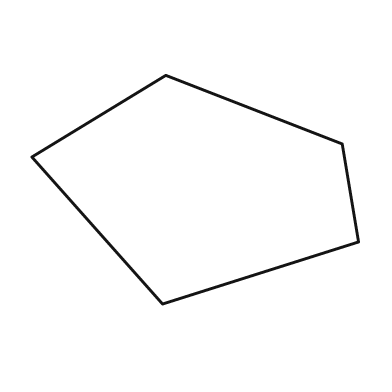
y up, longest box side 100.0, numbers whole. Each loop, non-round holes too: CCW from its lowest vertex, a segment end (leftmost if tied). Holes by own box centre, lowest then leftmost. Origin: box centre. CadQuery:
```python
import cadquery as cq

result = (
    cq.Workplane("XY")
    .moveTo(-10.0, -35.0)
    .lineTo(50.0, -16.0)
    .lineTo(45.0, 14.0)
    .lineTo(-9.0, 35.0)
    .lineTo(-50.0, 10.0)
    .close()
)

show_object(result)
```